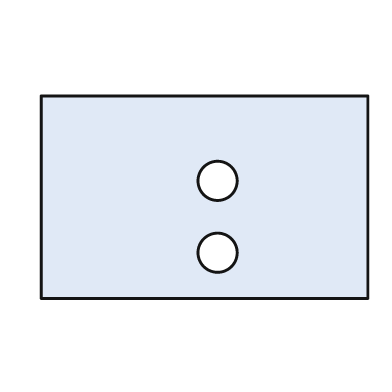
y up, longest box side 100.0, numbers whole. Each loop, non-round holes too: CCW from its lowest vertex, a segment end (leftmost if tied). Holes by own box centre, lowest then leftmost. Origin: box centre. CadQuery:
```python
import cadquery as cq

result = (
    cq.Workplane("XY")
    .moveTo(-50.0, -31.0)
    .lineTo(50.0, -31.0)
    .lineTo(50.0, 31.0)
    .lineTo(-50.0, 31.0)
    .close()
    .moveTo(4.0, -17.0)
    .circle(6.0)
    .moveTo(4.0, 5.0)
    .circle(6.0)
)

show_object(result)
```